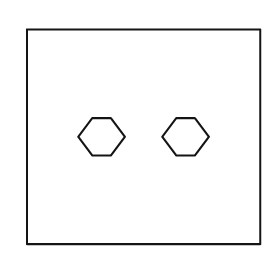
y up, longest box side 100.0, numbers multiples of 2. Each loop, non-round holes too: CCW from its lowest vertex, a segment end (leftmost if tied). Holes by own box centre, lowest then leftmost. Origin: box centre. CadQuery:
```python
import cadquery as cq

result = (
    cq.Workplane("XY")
    .moveTo(-50.0, -46.0)
    .lineTo(50.0, -46.0)
    .lineTo(50.0, 46.0)
    .lineTo(-50.0, 46.0)
    .close()
    .moveTo(-22.0, -8.0)
    .lineTo(-14.0, -8.0)
    .lineTo(-8.0, 0.0)
    .lineTo(-14.0, 8.0)
    .lineTo(-22.0, 8.0)
    .lineTo(-28.0, 0.0)
    .close()
    .moveTo(14.0, -8.0)
    .lineTo(22.0, -8.0)
    .lineTo(28.0, 0.0)
    .lineTo(22.0, 8.0)
    .lineTo(14.0, 8.0)
    .lineTo(8.0, 0.0)
    .close()
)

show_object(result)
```